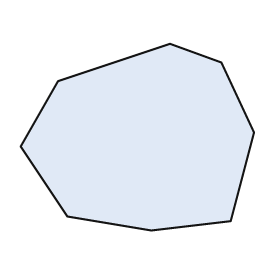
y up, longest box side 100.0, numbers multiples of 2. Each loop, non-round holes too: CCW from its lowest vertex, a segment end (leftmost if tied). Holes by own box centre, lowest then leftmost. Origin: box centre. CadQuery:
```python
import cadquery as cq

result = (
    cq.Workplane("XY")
    .moveTo(6.0, -40.0)
    .lineTo(40.0, -36.0)
    .lineTo(50.0, 2.0)
    .lineTo(36.0, 32.0)
    .lineTo(14.0, 40.0)
    .lineTo(-34.0, 24.0)
    .lineTo(-50.0, -4.0)
    .lineTo(-30.0, -34.0)
    .close()
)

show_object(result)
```